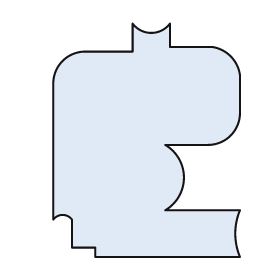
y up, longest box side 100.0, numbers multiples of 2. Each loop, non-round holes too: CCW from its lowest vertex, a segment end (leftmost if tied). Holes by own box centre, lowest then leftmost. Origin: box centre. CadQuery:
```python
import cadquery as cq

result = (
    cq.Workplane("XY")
    .moveTo(-22.0, -50.0)
    .lineTo(40.0, -50.0)
    .threePointArc((38.0, -40.0), (40.0, -30.0))
    .lineTo(8.0, -30.0)
    .threePointArc((16.0, -16.0), (8.0, -2.0))
    .lineTo(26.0, -2.0)
    .threePointArc((36.0, 2.0), (40.0, 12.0))
    .lineTo(40.0, 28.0)
    .threePointArc((36.0, 36.0), (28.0, 40.0))
    .lineTo(10.0, 40.0)
    .lineTo(10.0, 50.0)
    .threePointArc((2.0, 46.0), (-6.0, 50.0))
    .lineTo(-6.0, 38.0)
    .lineTo(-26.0, 38.0)
    .threePointArc((-36.0, 34.0), (-40.0, 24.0))
    .lineTo(-40.0, -34.0)
    .threePointArc((-36.0, -32.0), (-32.0, -34.0))
    .lineTo(-32.0, -46.0)
    .lineTo(-22.0, -46.0)
    .close()
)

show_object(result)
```